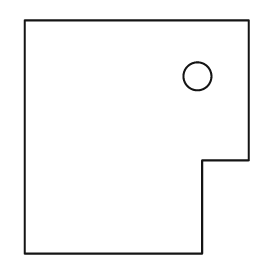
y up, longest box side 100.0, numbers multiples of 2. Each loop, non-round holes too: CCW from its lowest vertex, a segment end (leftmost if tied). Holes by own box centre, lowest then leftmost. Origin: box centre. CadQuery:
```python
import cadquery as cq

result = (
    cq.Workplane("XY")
    .moveTo(-48.0, -50.0)
    .lineTo(28.0, -50.0)
    .lineTo(28.0, -10.0)
    .lineTo(48.0, -10.0)
    .lineTo(48.0, 50.0)
    .lineTo(-48.0, 50.0)
    .close()
    .moveTo(26.0, 26.0)
    .circle(6.0)
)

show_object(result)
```